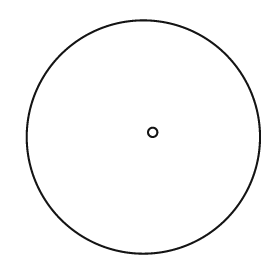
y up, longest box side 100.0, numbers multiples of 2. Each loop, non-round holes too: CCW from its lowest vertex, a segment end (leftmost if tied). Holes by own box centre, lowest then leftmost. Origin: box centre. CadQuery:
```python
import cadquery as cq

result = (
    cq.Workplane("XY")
    .moveTo(0.0, 0.0)
    .circle(50.0)
    .moveTo(4.0, 2.0)
    .circle(2.0)
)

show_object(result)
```